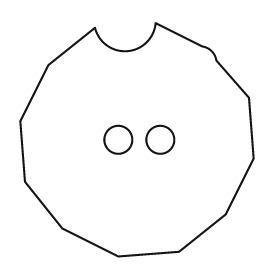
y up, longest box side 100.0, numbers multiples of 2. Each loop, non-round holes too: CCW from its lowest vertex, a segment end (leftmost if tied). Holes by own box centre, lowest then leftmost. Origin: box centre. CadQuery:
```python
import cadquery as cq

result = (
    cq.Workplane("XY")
    .moveTo(-8.0, -50.0)
    .lineTo(18.0, -48.0)
    .lineTo(38.0, -32.0)
    .lineTo(50.0, -8.0)
    .lineTo(48.0, 18.0)
    .lineTo(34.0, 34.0)
    .threePointArc((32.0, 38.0), (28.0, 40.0))
    .lineTo(8.0, 50.0)
    .threePointArc((-4.0, 38.0), (-18.0, 48.0))
    .lineTo(-38.0, 32.0)
    .lineTo(-50.0, 8.0)
    .lineTo(-48.0, -18.0)
    .lineTo(-32.0, -38.0)
    .close()
    .moveTo(-8.0, 0.0)
    .circle(6.0)
    .moveTo(10.0, 0.0)
    .circle(6.0)
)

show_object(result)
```